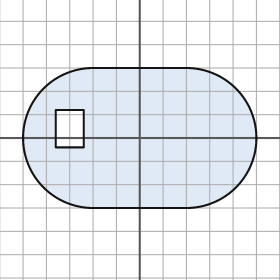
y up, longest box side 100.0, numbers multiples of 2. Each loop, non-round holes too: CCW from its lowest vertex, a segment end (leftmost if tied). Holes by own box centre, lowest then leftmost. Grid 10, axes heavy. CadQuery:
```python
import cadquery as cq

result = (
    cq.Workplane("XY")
    .moveTo(-20.0, -30.0)
    .lineTo(20.0, -30.0)
    .threePointArc((50.0, 0.0), (20.0, 30.0))
    .lineTo(-20.0, 30.0)
    .threePointArc((-50.0, 0.0), (-20.0, -30.0))
    .close()
    .moveTo(-36.0, -4.0)
    .lineTo(-24.0, -4.0)
    .lineTo(-24.0, 12.0)
    .lineTo(-36.0, 12.0)
    .close()
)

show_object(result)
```